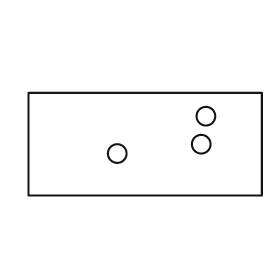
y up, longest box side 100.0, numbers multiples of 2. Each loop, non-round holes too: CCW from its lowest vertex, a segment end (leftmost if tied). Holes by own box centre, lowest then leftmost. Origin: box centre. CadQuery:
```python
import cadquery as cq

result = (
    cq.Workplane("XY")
    .moveTo(-50.0, -22.0)
    .lineTo(50.0, -22.0)
    .lineTo(50.0, 22.0)
    .lineTo(-50.0, 22.0)
    .close()
    .moveTo(-12.0, -4.0)
    .circle(4.0)
    .moveTo(24.0, 0.0)
    .circle(4.0)
    .moveTo(26.0, 12.0)
    .circle(4.0)
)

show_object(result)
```